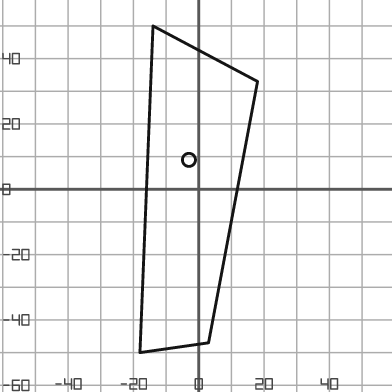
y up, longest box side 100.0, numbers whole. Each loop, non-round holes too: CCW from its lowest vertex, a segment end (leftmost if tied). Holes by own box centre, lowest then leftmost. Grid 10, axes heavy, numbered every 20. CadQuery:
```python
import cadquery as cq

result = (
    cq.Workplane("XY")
    .moveTo(-18.0, -50.0)
    .lineTo(3.0, -47.0)
    .lineTo(18.0, 33.0)
    .lineTo(-14.0, 50.0)
    .close()
    .moveTo(-3.0, 9.0)
    .circle(2.0)
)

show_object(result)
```